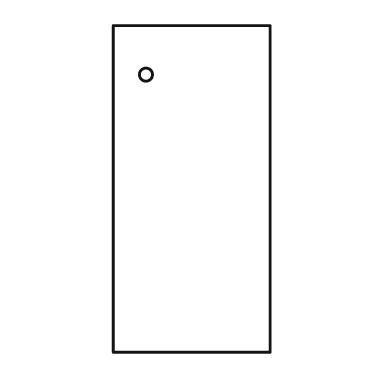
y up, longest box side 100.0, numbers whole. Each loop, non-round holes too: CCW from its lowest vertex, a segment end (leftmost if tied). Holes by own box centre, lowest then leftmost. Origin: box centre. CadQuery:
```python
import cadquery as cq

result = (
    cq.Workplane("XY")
    .moveTo(-24.0, -50.0)
    .lineTo(24.0, -50.0)
    .lineTo(24.0, 50.0)
    .lineTo(-24.0, 50.0)
    .close()
    .moveTo(-14.0, 35.0)
    .circle(2.0)
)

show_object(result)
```